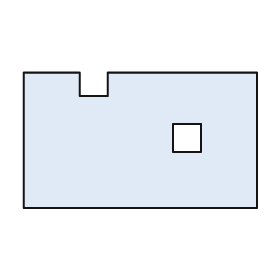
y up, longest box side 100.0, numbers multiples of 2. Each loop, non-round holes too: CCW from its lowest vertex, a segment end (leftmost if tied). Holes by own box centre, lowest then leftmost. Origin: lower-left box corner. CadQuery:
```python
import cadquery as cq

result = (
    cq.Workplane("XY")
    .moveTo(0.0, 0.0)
    .lineTo(100.0, 0.0)
    .lineTo(100.0, 58.0)
    .lineTo(36.0, 58.0)
    .lineTo(36.0, 48.0)
    .lineTo(24.0, 48.0)
    .lineTo(24.0, 58.0)
    .lineTo(0.0, 58.0)
    .close()
    .moveTo(64.0, 24.0)
    .lineTo(76.0, 24.0)
    .lineTo(76.0, 36.0)
    .lineTo(64.0, 36.0)
    .close()
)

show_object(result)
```